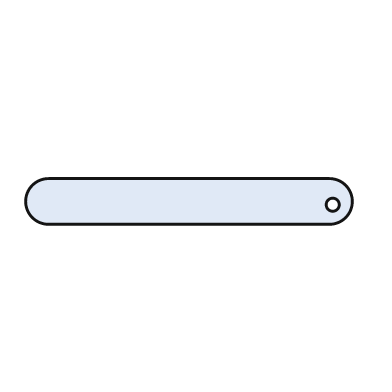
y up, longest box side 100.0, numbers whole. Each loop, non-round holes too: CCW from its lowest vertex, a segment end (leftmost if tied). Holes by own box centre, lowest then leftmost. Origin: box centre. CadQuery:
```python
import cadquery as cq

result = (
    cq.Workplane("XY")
    .moveTo(-43.0, -7.0)
    .lineTo(43.0, -7.0)
    .threePointArc((50.0, 0.0), (43.0, 7.0))
    .lineTo(-43.0, 7.0)
    .threePointArc((-50.0, 0.0), (-43.0, -7.0))
    .close()
    .moveTo(44.0, -1.0)
    .circle(2.0)
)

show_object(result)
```